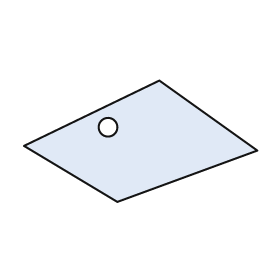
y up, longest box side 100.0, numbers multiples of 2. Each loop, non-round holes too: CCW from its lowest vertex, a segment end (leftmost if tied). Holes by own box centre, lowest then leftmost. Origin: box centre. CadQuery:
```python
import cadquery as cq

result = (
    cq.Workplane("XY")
    .moveTo(-10.0, -26.0)
    .lineTo(50.0, -4.0)
    .lineTo(8.0, 26.0)
    .lineTo(-50.0, -2.0)
    .close()
    .moveTo(-14.0, 6.0)
    .circle(4.0)
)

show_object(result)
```